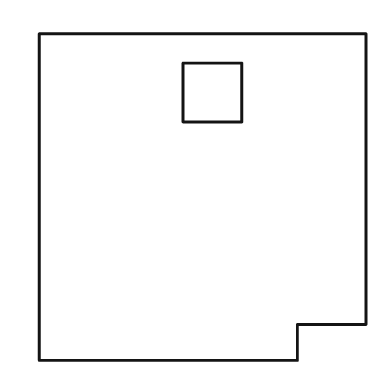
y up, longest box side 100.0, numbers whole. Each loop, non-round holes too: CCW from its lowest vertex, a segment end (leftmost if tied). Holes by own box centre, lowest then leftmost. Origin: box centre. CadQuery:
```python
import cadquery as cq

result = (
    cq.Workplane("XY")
    .moveTo(-50.0, -50.0)
    .lineTo(29.0, -50.0)
    .lineTo(29.0, -39.0)
    .lineTo(50.0, -39.0)
    .lineTo(50.0, 50.0)
    .lineTo(-50.0, 50.0)
    .close()
    .moveTo(-6.0, 23.0)
    .lineTo(12.0, 23.0)
    .lineTo(12.0, 41.0)
    .lineTo(-6.0, 41.0)
    .close()
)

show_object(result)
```